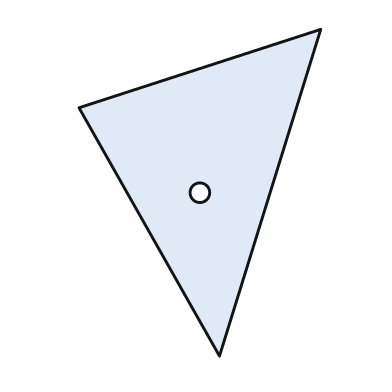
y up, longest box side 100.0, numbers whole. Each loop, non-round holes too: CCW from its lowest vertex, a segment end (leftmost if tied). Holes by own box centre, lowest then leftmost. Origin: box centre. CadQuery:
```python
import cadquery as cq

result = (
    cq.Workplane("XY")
    .moveTo(6.0, -50.0)
    .lineTo(37.0, 50.0)
    .lineTo(-37.0, 26.0)
    .close()
    .moveTo(0.0, 0.0)
    .circle(3.0)
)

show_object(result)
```